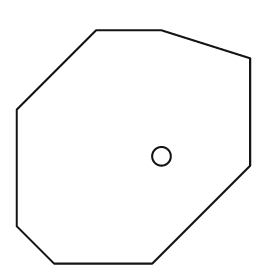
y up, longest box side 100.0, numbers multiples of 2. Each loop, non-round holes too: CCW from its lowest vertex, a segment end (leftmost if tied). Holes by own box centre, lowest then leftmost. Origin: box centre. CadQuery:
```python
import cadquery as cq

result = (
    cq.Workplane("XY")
    .moveTo(-34.0, -50.0)
    .lineTo(8.0, -50.0)
    .lineTo(50.0, -8.0)
    .lineTo(50.0, 38.0)
    .lineTo(12.0, 50.0)
    .lineTo(-16.0, 50.0)
    .lineTo(-50.0, 16.0)
    .lineTo(-50.0, -34.0)
    .close()
    .moveTo(12.0, -4.0)
    .circle(4.0)
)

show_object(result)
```